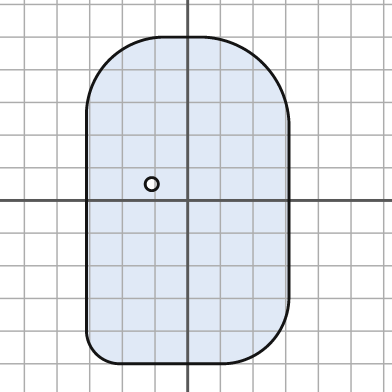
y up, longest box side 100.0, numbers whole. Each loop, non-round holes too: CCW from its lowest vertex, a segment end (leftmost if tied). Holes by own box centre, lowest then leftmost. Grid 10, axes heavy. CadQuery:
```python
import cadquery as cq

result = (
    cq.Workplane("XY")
    .moveTo(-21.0, -50.0)
    .lineTo(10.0, -50.0)
    .threePointArc((25.0, -44.0), (31.0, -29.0))
    .lineTo(31.0, 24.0)
    .threePointArc((23.0, 42.0), (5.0, 50.0))
    .lineTo(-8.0, 50.0)
    .threePointArc((-24.0, 43.0), (-31.0, 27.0))
    .lineTo(-31.0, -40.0)
    .threePointArc((-28.0, -47.0), (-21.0, -50.0))
    .close()
    .moveTo(-11.0, 5.0)
    .circle(2.0)
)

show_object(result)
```